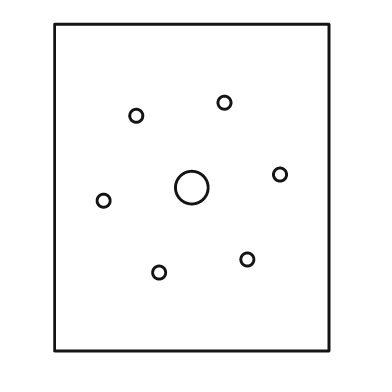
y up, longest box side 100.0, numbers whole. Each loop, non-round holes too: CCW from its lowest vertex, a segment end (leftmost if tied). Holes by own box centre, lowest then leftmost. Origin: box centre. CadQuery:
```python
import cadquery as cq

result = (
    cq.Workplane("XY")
    .moveTo(-42.0, -50.0)
    .lineTo(42.0, -50.0)
    .lineTo(42.0, 50.0)
    .lineTo(-42.0, 50.0)
    .close()
    .moveTo(-10.0, -26.0)
    .circle(2.0)
    .moveTo(17.0, -22.0)
    .circle(2.0)
    .moveTo(-27.0, -4.0)
    .circle(2.0)
    .moveTo(0.0, 0.0)
    .circle(5.0)
    .moveTo(27.0, 4.0)
    .circle(2.0)
    .moveTo(-17.0, 22.0)
    .circle(2.0)
    .moveTo(10.0, 26.0)
    .circle(2.0)
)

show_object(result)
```